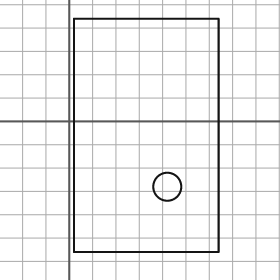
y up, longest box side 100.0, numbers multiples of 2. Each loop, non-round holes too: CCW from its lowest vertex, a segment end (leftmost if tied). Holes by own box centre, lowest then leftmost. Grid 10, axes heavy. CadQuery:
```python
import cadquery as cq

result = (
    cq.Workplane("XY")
    .moveTo(2.0, -56.0)
    .lineTo(64.0, -56.0)
    .lineTo(64.0, 44.0)
    .lineTo(2.0, 44.0)
    .close()
    .moveTo(42.0, -28.0)
    .circle(6.0)
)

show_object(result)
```